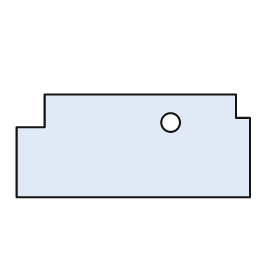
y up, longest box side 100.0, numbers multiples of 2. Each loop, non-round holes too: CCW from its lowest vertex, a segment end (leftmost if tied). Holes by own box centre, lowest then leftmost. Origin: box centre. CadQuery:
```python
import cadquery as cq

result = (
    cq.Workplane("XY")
    .moveTo(-50.0, -22.0)
    .lineTo(50.0, -22.0)
    .lineTo(50.0, 12.0)
    .lineTo(44.0, 12.0)
    .lineTo(44.0, 22.0)
    .lineTo(-38.0, 22.0)
    .lineTo(-38.0, 8.0)
    .lineTo(-50.0, 8.0)
    .close()
    .moveTo(16.0, 10.0)
    .circle(4.0)
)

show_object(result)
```